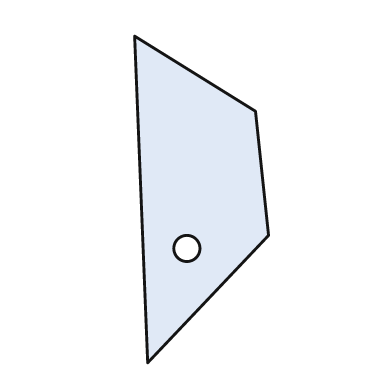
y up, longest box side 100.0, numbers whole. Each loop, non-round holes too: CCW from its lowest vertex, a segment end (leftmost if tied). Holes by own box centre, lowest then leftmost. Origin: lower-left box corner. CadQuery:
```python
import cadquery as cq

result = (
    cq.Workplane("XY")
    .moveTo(4.0, 0.0)
    .lineTo(41.0, 39.0)
    .lineTo(37.0, 77.0)
    .lineTo(0.0, 100.0)
    .close()
    .moveTo(16.0, 35.0)
    .circle(4.0)
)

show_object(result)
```